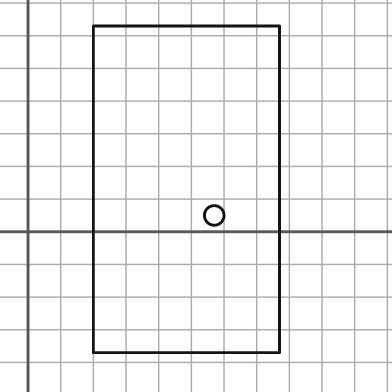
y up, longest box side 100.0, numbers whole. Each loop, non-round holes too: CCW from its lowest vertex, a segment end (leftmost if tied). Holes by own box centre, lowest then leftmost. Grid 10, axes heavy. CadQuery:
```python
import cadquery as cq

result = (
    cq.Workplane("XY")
    .moveTo(20.0, -37.0)
    .lineTo(77.0, -37.0)
    .lineTo(77.0, 63.0)
    .lineTo(20.0, 63.0)
    .close()
    .moveTo(57.0, 5.0)
    .circle(3.0)
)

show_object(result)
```